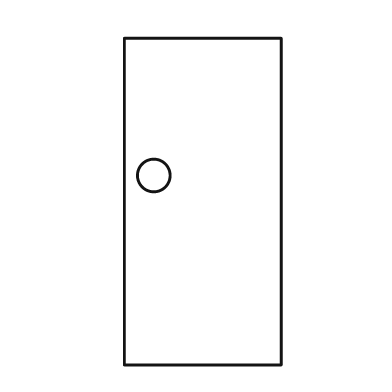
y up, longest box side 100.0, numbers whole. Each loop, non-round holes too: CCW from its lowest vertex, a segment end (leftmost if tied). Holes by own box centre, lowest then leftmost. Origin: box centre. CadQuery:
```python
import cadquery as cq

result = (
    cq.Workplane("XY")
    .moveTo(-24.0, -50.0)
    .lineTo(24.0, -50.0)
    .lineTo(24.0, 50.0)
    .lineTo(-24.0, 50.0)
    .close()
    .moveTo(-15.0, 8.0)
    .circle(5.0)
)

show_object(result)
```